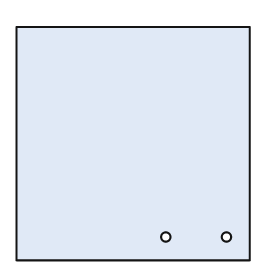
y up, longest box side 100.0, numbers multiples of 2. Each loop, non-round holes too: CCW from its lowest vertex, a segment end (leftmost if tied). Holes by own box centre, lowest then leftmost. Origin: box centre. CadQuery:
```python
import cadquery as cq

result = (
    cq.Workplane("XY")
    .moveTo(-50.0, -50.0)
    .lineTo(50.0, -50.0)
    .lineTo(50.0, 50.0)
    .lineTo(-50.0, 50.0)
    .close()
    .moveTo(14.0, -40.0)
    .circle(2.0)
    .moveTo(40.0, -40.0)
    .circle(2.0)
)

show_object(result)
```